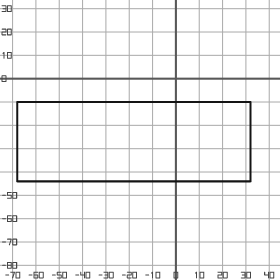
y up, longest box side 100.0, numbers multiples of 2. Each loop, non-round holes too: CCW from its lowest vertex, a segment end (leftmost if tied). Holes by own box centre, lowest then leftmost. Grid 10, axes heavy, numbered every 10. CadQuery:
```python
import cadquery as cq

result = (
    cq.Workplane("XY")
    .moveTo(-68.0, -44.0)
    .lineTo(32.0, -44.0)
    .lineTo(32.0, -10.0)
    .lineTo(-68.0, -10.0)
    .close()
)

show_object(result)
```